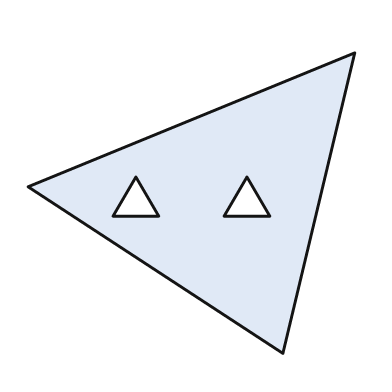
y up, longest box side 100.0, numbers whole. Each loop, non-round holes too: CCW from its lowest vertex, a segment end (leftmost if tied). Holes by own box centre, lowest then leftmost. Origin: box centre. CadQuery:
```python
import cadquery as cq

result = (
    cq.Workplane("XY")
    .moveTo(28.0, -46.0)
    .lineTo(50.0, 46.0)
    .lineTo(-50.0, 5.0)
    .close()
    .moveTo(-24.0, -4.0)
    .lineTo(-10.0, -4.0)
    .lineTo(-17.0, 8.0)
    .close()
    .moveTo(10.0, -4.0)
    .lineTo(24.0, -4.0)
    .lineTo(17.0, 8.0)
    .close()
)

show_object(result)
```